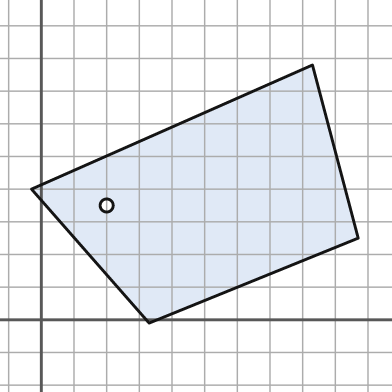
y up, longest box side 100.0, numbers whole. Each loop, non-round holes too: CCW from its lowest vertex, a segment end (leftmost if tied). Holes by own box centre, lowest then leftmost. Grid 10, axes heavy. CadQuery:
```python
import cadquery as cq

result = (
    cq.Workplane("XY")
    .moveTo(33.0, -1.0)
    .lineTo(97.0, 25.0)
    .lineTo(83.0, 78.0)
    .lineTo(-3.0, 40.0)
    .close()
    .moveTo(20.0, 35.0)
    .circle(2.0)
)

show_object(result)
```